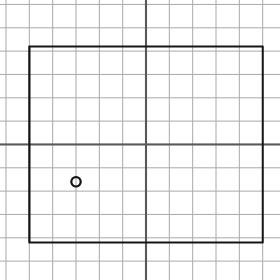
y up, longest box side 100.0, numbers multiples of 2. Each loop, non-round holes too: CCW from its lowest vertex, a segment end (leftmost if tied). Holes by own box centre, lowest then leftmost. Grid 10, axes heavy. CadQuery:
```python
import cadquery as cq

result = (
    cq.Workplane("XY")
    .moveTo(-50.0, -42.0)
    .lineTo(50.0, -42.0)
    .lineTo(50.0, 42.0)
    .lineTo(-50.0, 42.0)
    .close()
    .moveTo(-30.0, -16.0)
    .circle(2.0)
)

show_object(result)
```